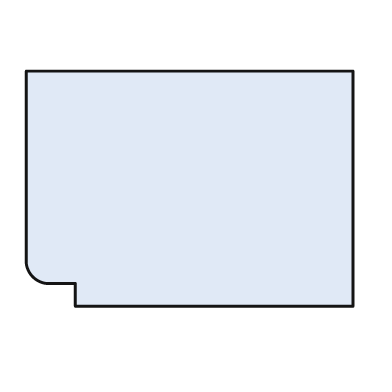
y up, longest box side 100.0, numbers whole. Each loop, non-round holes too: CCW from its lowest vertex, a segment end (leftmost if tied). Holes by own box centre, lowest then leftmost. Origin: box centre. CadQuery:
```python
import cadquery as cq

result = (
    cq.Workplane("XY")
    .moveTo(-35.0, -36.0)
    .lineTo(50.0, -36.0)
    .lineTo(50.0, 36.0)
    .lineTo(-50.0, 36.0)
    .lineTo(-50.0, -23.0)
    .threePointArc((-48.0, -27.0), (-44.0, -29.0))
    .lineTo(-35.0, -29.0)
    .close()
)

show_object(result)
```